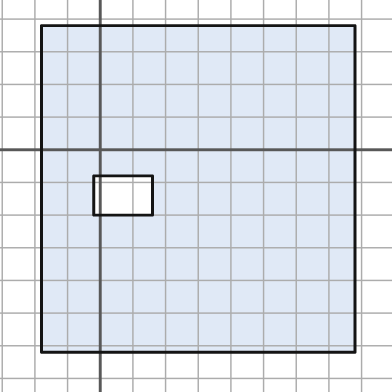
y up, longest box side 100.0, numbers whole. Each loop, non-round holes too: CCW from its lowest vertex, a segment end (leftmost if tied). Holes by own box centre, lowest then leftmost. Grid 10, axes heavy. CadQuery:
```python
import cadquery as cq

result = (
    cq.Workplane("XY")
    .moveTo(-18.0, -62.0)
    .lineTo(78.0, -62.0)
    .lineTo(78.0, 38.0)
    .lineTo(-18.0, 38.0)
    .close()
    .moveTo(-2.0, -20.0)
    .lineTo(16.0, -20.0)
    .lineTo(16.0, -8.0)
    .lineTo(-2.0, -8.0)
    .close()
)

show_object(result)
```